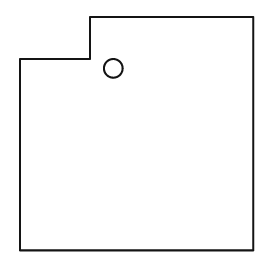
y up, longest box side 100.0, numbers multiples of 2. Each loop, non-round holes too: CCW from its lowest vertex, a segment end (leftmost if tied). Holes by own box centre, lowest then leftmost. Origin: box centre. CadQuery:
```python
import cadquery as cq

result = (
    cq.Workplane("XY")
    .moveTo(-50.0, -50.0)
    .lineTo(50.0, -50.0)
    .lineTo(50.0, 50.0)
    .lineTo(-20.0, 50.0)
    .lineTo(-20.0, 32.0)
    .lineTo(-50.0, 32.0)
    .close()
    .moveTo(-10.0, 28.0)
    .circle(4.0)
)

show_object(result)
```